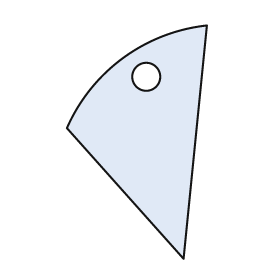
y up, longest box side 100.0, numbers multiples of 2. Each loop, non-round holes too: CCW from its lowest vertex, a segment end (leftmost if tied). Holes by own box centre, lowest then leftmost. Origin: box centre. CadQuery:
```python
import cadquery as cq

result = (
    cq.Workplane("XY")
    .moveTo(20.0, -50.0)
    .lineTo(30.0, 50.0)
    .threePointArc((-6.0, 36.0), (-30.0, 6.0))
    .close()
    .moveTo(4.0, 28.0)
    .circle(6.0)
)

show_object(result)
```